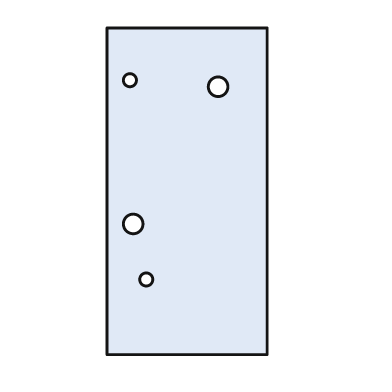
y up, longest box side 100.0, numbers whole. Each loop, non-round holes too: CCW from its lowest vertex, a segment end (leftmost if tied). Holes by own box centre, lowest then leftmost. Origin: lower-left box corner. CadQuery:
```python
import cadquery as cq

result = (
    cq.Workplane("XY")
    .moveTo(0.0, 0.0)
    .lineTo(49.0, 0.0)
    .lineTo(49.0, 100.0)
    .lineTo(0.0, 100.0)
    .close()
    .moveTo(12.0, 23.0)
    .circle(2.0)
    .moveTo(8.0, 40.0)
    .circle(3.0)
    .moveTo(34.0, 82.0)
    .circle(3.0)
    .moveTo(7.0, 84.0)
    .circle(2.0)
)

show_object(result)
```